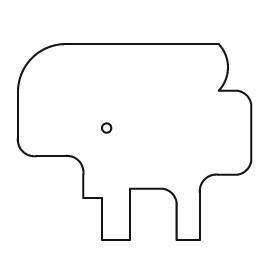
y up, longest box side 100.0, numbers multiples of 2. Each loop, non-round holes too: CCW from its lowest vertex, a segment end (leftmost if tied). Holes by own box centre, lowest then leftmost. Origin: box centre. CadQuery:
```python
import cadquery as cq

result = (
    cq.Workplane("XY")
    .moveTo(-14.0, -42.0)
    .lineTo(-2.0, -42.0)
    .lineTo(-2.0, -20.0)
    .lineTo(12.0, -20.0)
    .threePointArc((16.0, -22.0), (18.0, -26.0))
    .lineTo(18.0, -42.0)
    .lineTo(28.0, -42.0)
    .lineTo(28.0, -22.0)
    .threePointArc((30.0, -16.0), (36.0, -14.0))
    .lineTo(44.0, -14.0)
    .threePointArc((48.0, -12.0), (50.0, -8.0))
    .lineTo(50.0, 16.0)
    .threePointArc((48.0, 20.0), (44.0, 22.0))
    .lineTo(36.0, 22.0)
    .threePointArc((40.0, 32.0), (36.0, 42.0))
    .lineTo(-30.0, 42.0)
    .threePointArc((-44.0, 36.0), (-50.0, 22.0))
    .lineTo(-50.0, 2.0)
    .threePointArc((-48.0, -4.0), (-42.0, -6.0))
    .lineTo(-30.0, -6.0)
    .threePointArc((-24.0, -8.0), (-22.0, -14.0))
    .lineTo(-22.0, -24.0)
    .lineTo(-14.0, -24.0)
    .close()
    .moveTo(-12.0, 6.0)
    .circle(2.0)
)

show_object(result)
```